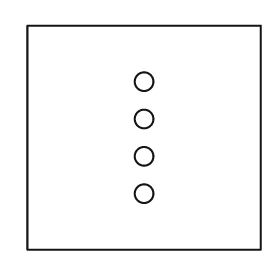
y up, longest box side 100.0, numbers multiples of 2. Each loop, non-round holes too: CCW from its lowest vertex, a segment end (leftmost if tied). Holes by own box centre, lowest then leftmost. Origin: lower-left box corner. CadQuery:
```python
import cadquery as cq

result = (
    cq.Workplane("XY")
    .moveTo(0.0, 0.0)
    .lineTo(100.0, 0.0)
    .lineTo(100.0, 96.0)
    .lineTo(0.0, 96.0)
    .close()
    .moveTo(50.0, 24.0)
    .circle(4.0)
    .moveTo(50.0, 40.0)
    .circle(4.0)
    .moveTo(50.0, 56.0)
    .circle(4.0)
    .moveTo(50.0, 72.0)
    .circle(4.0)
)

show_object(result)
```